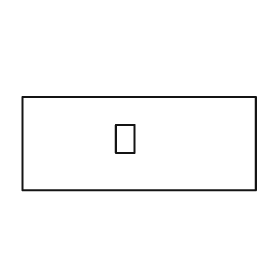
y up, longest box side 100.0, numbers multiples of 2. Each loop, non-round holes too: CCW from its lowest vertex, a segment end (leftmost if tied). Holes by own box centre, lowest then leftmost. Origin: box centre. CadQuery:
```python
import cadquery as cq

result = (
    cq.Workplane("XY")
    .moveTo(-50.0, -20.0)
    .lineTo(50.0, -20.0)
    .lineTo(50.0, 20.0)
    .lineTo(-50.0, 20.0)
    .close()
    .moveTo(-10.0, -4.0)
    .lineTo(-2.0, -4.0)
    .lineTo(-2.0, 8.0)
    .lineTo(-10.0, 8.0)
    .close()
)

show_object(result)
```